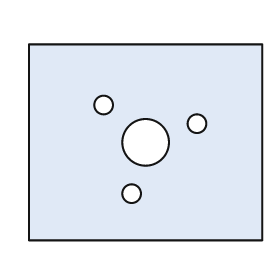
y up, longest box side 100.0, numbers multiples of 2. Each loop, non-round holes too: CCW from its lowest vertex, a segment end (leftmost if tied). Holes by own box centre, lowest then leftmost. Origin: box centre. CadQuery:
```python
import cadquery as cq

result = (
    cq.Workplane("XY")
    .moveTo(-50.0, -42.0)
    .lineTo(50.0, -42.0)
    .lineTo(50.0, 42.0)
    .lineTo(-50.0, 42.0)
    .close()
    .moveTo(-6.0, -22.0)
    .circle(4.0)
    .moveTo(0.0, 0.0)
    .circle(10.0)
    .moveTo(22.0, 8.0)
    .circle(4.0)
    .moveTo(-18.0, 16.0)
    .circle(4.0)
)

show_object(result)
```